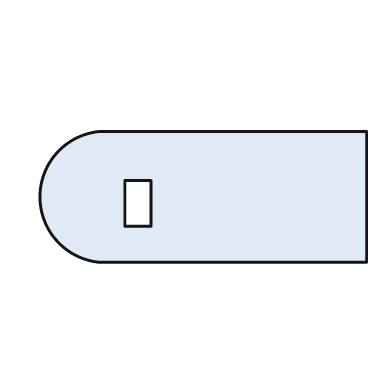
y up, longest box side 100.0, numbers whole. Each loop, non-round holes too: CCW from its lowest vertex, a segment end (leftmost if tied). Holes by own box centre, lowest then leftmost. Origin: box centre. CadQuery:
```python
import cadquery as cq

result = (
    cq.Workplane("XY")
    .moveTo(-32.0, -20.0)
    .lineTo(50.0, -20.0)
    .lineTo(50.0, 20.0)
    .lineTo(-32.0, 20.0)
    .threePointArc((-50.0, 0.0), (-32.0, -20.0))
    .close()
    .moveTo(-24.0, -9.0)
    .lineTo(-16.0, -9.0)
    .lineTo(-16.0, 5.0)
    .lineTo(-24.0, 5.0)
    .close()
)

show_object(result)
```